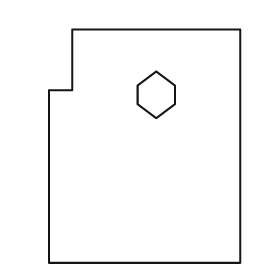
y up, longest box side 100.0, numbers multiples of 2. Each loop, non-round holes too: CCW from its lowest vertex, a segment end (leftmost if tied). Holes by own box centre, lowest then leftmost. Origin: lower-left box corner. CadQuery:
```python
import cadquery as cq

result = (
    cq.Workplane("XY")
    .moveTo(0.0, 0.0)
    .lineTo(82.0, 0.0)
    .lineTo(82.0, 100.0)
    .lineTo(10.0, 100.0)
    .lineTo(10.0, 74.0)
    .lineTo(0.0, 74.0)
    .close()
    .moveTo(46.0, 62.0)
    .lineTo(54.0, 68.0)
    .lineTo(54.0, 76.0)
    .lineTo(46.0, 82.0)
    .lineTo(38.0, 76.0)
    .lineTo(38.0, 68.0)
    .close()
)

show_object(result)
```